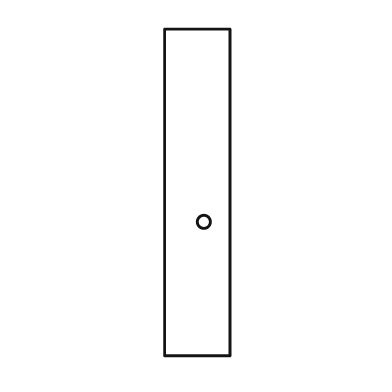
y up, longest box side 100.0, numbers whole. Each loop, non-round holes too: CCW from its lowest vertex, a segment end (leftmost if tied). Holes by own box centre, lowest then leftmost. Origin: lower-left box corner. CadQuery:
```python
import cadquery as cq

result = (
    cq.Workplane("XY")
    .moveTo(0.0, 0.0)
    .lineTo(20.0, 0.0)
    .lineTo(20.0, 100.0)
    .lineTo(0.0, 100.0)
    .close()
    .moveTo(12.0, 41.0)
    .circle(2.0)
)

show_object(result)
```